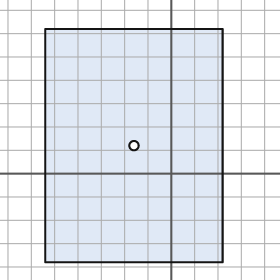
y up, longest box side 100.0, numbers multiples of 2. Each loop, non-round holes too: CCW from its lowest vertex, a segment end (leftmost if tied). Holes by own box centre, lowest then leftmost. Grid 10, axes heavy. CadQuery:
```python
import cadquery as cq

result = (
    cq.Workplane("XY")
    .moveTo(-54.0, -38.0)
    .lineTo(22.0, -38.0)
    .lineTo(22.0, 62.0)
    .lineTo(-54.0, 62.0)
    .close()
    .moveTo(-16.0, 12.0)
    .circle(2.0)
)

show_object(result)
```